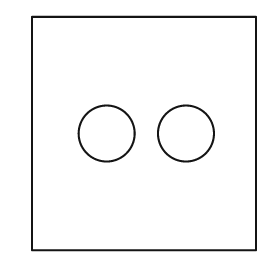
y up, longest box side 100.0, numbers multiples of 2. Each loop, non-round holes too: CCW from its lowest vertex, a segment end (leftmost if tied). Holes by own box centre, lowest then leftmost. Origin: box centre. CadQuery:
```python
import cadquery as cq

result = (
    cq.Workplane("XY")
    .moveTo(-48.0, -50.0)
    .lineTo(48.0, -50.0)
    .lineTo(48.0, 50.0)
    .lineTo(-48.0, 50.0)
    .close()
    .moveTo(-16.0, 0.0)
    .circle(12.0)
    .moveTo(18.0, 0.0)
    .circle(12.0)
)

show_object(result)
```